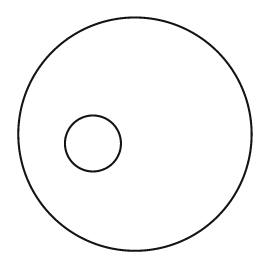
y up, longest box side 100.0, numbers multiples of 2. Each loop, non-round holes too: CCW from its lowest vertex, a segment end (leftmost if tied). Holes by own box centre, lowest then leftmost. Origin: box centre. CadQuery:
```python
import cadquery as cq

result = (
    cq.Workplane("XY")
    .moveTo(0.0, 0.0)
    .circle(50.0)
    .moveTo(-18.0, -4.0)
    .circle(12.0)
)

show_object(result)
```